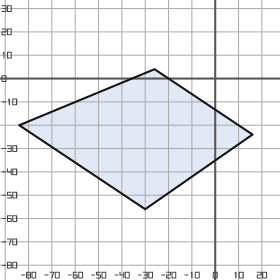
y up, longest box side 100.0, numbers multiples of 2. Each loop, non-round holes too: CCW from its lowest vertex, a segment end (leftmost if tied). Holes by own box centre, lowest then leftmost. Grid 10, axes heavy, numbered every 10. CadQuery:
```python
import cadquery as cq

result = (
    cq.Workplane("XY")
    .moveTo(-30.0, -56.0)
    .lineTo(16.0, -24.0)
    .lineTo(-26.0, 4.0)
    .lineTo(-84.0, -20.0)
    .close()
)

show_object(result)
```